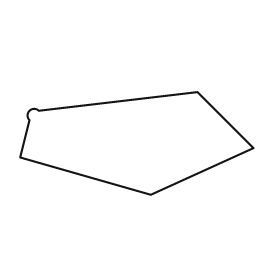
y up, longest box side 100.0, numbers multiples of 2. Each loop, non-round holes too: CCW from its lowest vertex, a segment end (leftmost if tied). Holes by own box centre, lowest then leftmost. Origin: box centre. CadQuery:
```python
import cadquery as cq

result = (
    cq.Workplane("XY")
    .moveTo(6.0, -22.0)
    .lineTo(50.0, -2.0)
    .lineTo(26.0, 22.0)
    .lineTo(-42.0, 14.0)
    .threePointArc((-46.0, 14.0), (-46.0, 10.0))
    .lineTo(-50.0, -6.0)
    .close()
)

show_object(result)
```